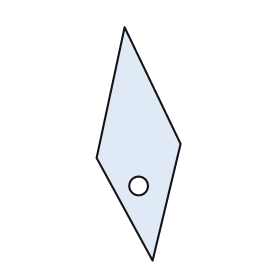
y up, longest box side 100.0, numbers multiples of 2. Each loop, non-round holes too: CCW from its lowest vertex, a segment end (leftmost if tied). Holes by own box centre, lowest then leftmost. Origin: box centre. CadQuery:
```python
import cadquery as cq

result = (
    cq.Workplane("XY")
    .moveTo(6.0, -50.0)
    .lineTo(18.0, 0.0)
    .lineTo(-6.0, 50.0)
    .lineTo(-18.0, -6.0)
    .close()
    .moveTo(0.0, -18.0)
    .circle(4.0)
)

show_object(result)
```